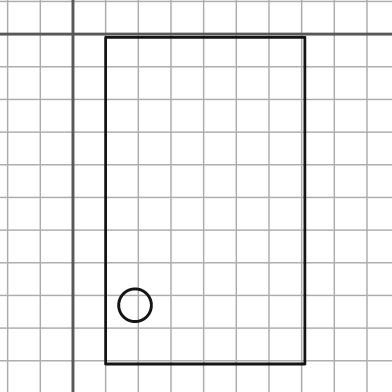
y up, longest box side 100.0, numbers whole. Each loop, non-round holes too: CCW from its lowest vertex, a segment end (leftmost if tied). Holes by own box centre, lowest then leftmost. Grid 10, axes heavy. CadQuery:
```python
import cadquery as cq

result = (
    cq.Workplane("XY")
    .moveTo(10.0, -101.0)
    .lineTo(71.0, -101.0)
    .lineTo(71.0, -1.0)
    .lineTo(10.0, -1.0)
    .close()
    .moveTo(19.0, -83.0)
    .circle(5.0)
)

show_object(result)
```